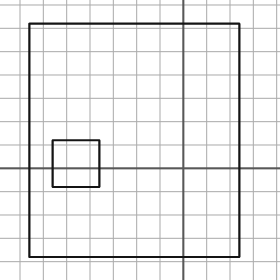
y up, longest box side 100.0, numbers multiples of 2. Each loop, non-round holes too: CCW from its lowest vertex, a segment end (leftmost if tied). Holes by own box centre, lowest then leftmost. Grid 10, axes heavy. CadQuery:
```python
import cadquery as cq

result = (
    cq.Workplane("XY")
    .moveTo(-66.0, -38.0)
    .lineTo(24.0, -38.0)
    .lineTo(24.0, 62.0)
    .lineTo(-66.0, 62.0)
    .close()
    .moveTo(-56.0, -8.0)
    .lineTo(-36.0, -8.0)
    .lineTo(-36.0, 12.0)
    .lineTo(-56.0, 12.0)
    .close()
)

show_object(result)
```